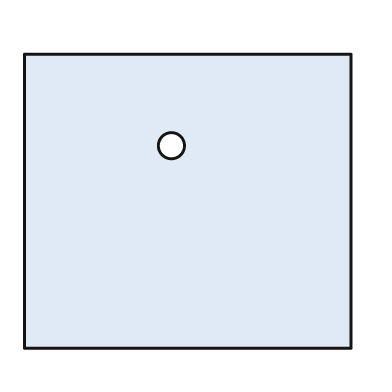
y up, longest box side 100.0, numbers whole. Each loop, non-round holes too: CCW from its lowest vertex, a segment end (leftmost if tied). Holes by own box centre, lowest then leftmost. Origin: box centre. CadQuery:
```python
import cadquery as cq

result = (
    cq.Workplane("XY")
    .moveTo(-50.0, -45.0)
    .lineTo(50.0, -45.0)
    .lineTo(50.0, 45.0)
    .lineTo(-50.0, 45.0)
    .close()
    .moveTo(-5.0, 17.0)
    .circle(4.0)
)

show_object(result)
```